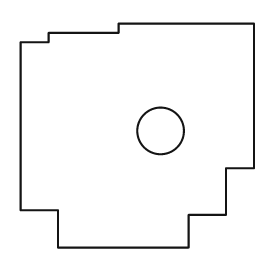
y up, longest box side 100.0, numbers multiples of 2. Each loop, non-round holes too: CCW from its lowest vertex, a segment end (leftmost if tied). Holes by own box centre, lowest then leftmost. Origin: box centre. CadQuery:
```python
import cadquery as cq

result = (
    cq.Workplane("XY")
    .moveTo(-34.0, -48.0)
    .lineTo(22.0, -48.0)
    .lineTo(22.0, -34.0)
    .lineTo(38.0, -34.0)
    .lineTo(38.0, -14.0)
    .lineTo(50.0, -14.0)
    .lineTo(50.0, 48.0)
    .lineTo(-8.0, 48.0)
    .lineTo(-8.0, 44.0)
    .lineTo(-38.0, 44.0)
    .lineTo(-38.0, 40.0)
    .lineTo(-50.0, 40.0)
    .lineTo(-50.0, -32.0)
    .lineTo(-34.0, -32.0)
    .close()
    .moveTo(10.0, 2.0)
    .circle(10.0)
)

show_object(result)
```